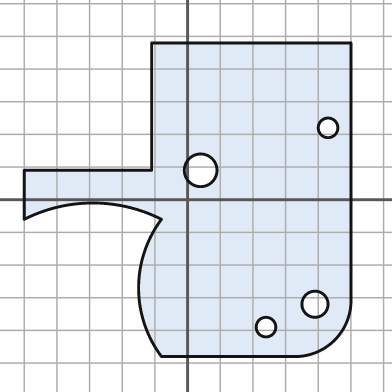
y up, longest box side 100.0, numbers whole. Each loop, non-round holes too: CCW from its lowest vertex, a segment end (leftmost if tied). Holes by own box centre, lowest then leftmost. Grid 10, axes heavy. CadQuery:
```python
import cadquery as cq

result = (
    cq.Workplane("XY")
    .moveTo(-8.0, -48.0)
    .lineTo(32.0, -48.0)
    .threePointArc((45.0, -43.0), (50.0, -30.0))
    .lineTo(50.0, 48.0)
    .lineTo(-11.0, 48.0)
    .lineTo(-11.0, 9.0)
    .lineTo(-50.0, 9.0)
    .lineTo(-50.0, -6.0)
    .threePointArc((-29.0, -1.0), (-8.0, -6.0))
    .threePointArc((-15.0, -27.0), (-8.0, -48.0))
    .close()
    .moveTo(24.0, -39.0)
    .circle(3.0)
    .moveTo(39.0, -32.0)
    .circle(4.0)
    .moveTo(4.0, 9.0)
    .circle(5.0)
    .moveTo(43.0, 22.0)
    .circle(3.0)
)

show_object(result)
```